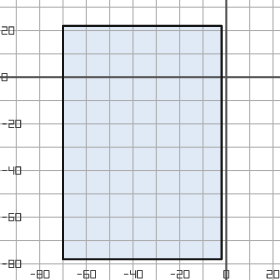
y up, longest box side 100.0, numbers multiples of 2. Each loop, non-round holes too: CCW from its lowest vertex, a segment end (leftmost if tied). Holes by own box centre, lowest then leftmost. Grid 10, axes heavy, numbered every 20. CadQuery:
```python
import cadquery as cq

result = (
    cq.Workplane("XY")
    .moveTo(-70.0, -78.0)
    .lineTo(-2.0, -78.0)
    .lineTo(-2.0, 22.0)
    .lineTo(-70.0, 22.0)
    .close()
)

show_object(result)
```